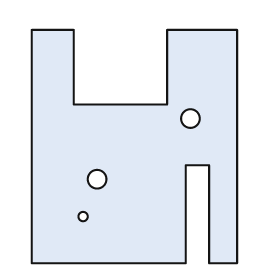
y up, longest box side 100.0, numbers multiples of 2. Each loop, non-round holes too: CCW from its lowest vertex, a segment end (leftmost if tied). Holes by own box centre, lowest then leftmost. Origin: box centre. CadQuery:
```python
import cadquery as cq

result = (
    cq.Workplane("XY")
    .moveTo(-44.0, -50.0)
    .lineTo(22.0, -50.0)
    .lineTo(22.0, -8.0)
    .lineTo(32.0, -8.0)
    .lineTo(32.0, -50.0)
    .lineTo(44.0, -50.0)
    .lineTo(44.0, 50.0)
    .lineTo(14.0, 50.0)
    .lineTo(14.0, 18.0)
    .lineTo(-26.0, 18.0)
    .lineTo(-26.0, 50.0)
    .lineTo(-44.0, 50.0)
    .close()
    .moveTo(-22.0, -30.0)
    .circle(2.0)
    .moveTo(-16.0, -14.0)
    .circle(4.0)
    .moveTo(24.0, 12.0)
    .circle(4.0)
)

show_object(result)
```